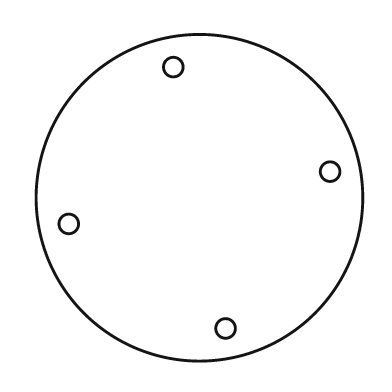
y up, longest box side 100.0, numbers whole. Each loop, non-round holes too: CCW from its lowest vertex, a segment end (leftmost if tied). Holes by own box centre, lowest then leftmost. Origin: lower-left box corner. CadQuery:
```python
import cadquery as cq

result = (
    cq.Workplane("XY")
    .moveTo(50.0, 50.0)
    .circle(50.0)
    .moveTo(58.0, 10.0)
    .circle(3.0)
    .moveTo(10.0, 42.0)
    .circle(3.0)
    .moveTo(90.0, 58.0)
    .circle(3.0)
    .moveTo(42.0, 90.0)
    .circle(3.0)
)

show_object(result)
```